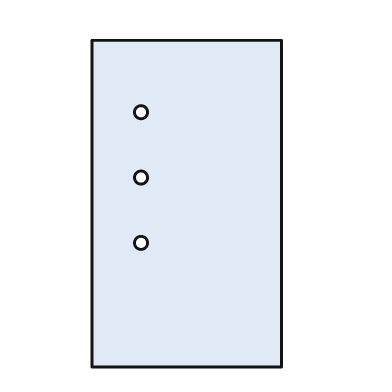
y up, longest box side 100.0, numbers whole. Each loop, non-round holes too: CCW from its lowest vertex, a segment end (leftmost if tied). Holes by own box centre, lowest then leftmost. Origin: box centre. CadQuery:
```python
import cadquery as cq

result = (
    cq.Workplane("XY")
    .moveTo(-29.0, -50.0)
    .lineTo(29.0, -50.0)
    .lineTo(29.0, 50.0)
    .lineTo(-29.0, 50.0)
    .close()
    .moveTo(-14.0, -12.0)
    .circle(2.0)
    .moveTo(-14.0, 8.0)
    .circle(2.0)
    .moveTo(-14.0, 28.0)
    .circle(2.0)
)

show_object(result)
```